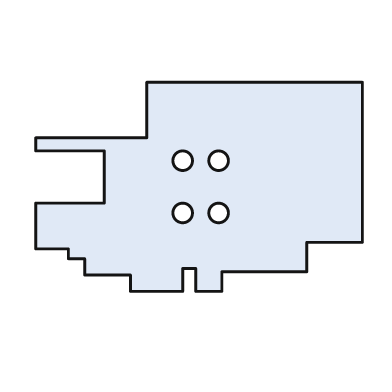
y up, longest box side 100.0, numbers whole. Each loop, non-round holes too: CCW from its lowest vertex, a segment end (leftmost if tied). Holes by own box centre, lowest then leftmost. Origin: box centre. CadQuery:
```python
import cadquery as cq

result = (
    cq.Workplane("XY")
    .moveTo(-21.0, -32.0)
    .lineTo(-5.0, -32.0)
    .lineTo(-5.0, -25.0)
    .lineTo(-1.0, -25.0)
    .lineTo(-1.0, -32.0)
    .lineTo(7.0, -32.0)
    .lineTo(7.0, -26.0)
    .lineTo(33.0, -26.0)
    .lineTo(33.0, -17.0)
    .lineTo(50.0, -17.0)
    .lineTo(50.0, 32.0)
    .lineTo(-16.0, 32.0)
    .lineTo(-16.0, 15.0)
    .lineTo(-50.0, 15.0)
    .lineTo(-50.0, 11.0)
    .lineTo(-29.0, 11.0)
    .lineTo(-29.0, -5.0)
    .lineTo(-50.0, -5.0)
    .lineTo(-50.0, -19.0)
    .lineTo(-40.0, -19.0)
    .lineTo(-40.0, -22.0)
    .lineTo(-35.0, -22.0)
    .lineTo(-35.0, -27.0)
    .lineTo(-21.0, -27.0)
    .close()
    .moveTo(-5.0, -8.0)
    .circle(3.0)
    .moveTo(6.0, -8.0)
    .circle(3.0)
    .moveTo(-5.0, 8.0)
    .circle(3.0)
    .moveTo(6.0, 8.0)
    .circle(3.0)
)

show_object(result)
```